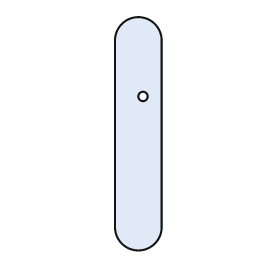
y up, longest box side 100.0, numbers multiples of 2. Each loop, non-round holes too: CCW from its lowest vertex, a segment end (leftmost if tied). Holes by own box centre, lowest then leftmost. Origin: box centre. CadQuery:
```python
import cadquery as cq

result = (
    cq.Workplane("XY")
    .moveTo(-10.0, -40.0)
    .threePointArc((0.0, -50.0), (10.0, -40.0))
    .lineTo(10.0, 40.0)
    .threePointArc((0.0, 50.0), (-10.0, 40.0))
    .close()
    .moveTo(2.0, 16.0)
    .circle(2.0)
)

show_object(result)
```